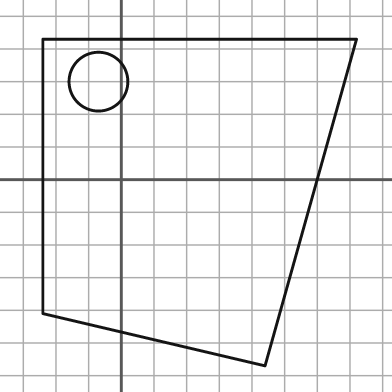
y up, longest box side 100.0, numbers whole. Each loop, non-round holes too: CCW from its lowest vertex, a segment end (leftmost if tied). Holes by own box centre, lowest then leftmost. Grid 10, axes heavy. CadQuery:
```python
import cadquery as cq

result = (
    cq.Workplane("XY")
    .moveTo(44.0, -57.0)
    .lineTo(72.0, 43.0)
    .lineTo(-24.0, 43.0)
    .lineTo(-24.0, -41.0)
    .close()
    .moveTo(-7.0, 30.0)
    .circle(9.0)
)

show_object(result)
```